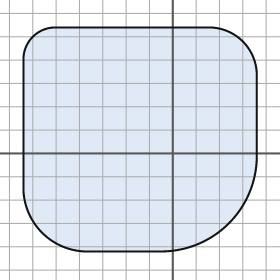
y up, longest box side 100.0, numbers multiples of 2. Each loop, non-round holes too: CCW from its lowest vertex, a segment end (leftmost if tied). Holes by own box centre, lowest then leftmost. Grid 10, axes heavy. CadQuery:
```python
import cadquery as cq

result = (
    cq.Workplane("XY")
    .moveTo(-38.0, -42.0)
    .lineTo(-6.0, -42.0)
    .threePointArc((24.0, -30.0), (36.0, 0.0))
    .lineTo(36.0, 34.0)
    .threePointArc((30.0, 48.0), (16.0, 54.0))
    .lineTo(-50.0, 54.0)
    .threePointArc((-60.0, 50.0), (-64.0, 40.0))
    .lineTo(-64.0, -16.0)
    .threePointArc((-56.0, -34.0), (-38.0, -42.0))
    .close()
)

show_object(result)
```